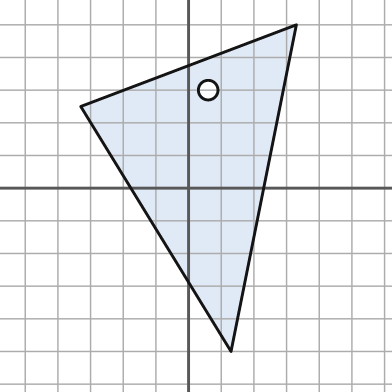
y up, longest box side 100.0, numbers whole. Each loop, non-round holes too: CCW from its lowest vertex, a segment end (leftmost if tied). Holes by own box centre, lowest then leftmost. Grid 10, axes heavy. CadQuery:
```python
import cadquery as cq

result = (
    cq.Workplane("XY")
    .moveTo(13.0, -50.0)
    .lineTo(33.0, 50.0)
    .lineTo(-33.0, 25.0)
    .close()
    .moveTo(6.0, 30.0)
    .circle(3.0)
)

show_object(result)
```